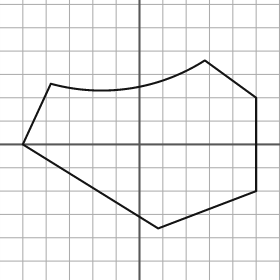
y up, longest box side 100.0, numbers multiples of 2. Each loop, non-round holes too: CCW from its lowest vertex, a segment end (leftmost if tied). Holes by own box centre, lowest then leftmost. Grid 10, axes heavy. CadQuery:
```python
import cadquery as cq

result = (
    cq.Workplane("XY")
    .moveTo(8.0, -36.0)
    .lineTo(50.0, -20.0)
    .lineTo(50.0, 20.0)
    .lineTo(28.0, 36.0)
    .threePointArc((-4.0, 24.0), (-38.0, 26.0))
    .lineTo(-50.0, 0.0)
    .close()
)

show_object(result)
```